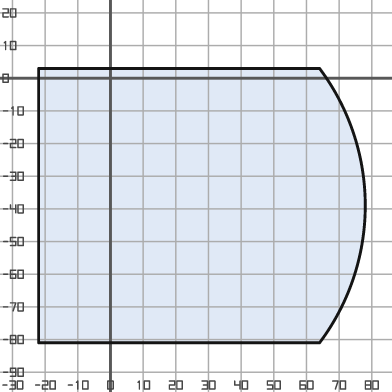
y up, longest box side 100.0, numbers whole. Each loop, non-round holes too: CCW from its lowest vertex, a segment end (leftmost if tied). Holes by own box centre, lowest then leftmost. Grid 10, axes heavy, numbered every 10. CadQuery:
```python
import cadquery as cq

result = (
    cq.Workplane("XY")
    .moveTo(-22.0, -81.0)
    .lineTo(64.0, -81.0)
    .threePointArc((78.0, -39.0), (64.0, 3.0))
    .lineTo(-22.0, 3.0)
    .close()
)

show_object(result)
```